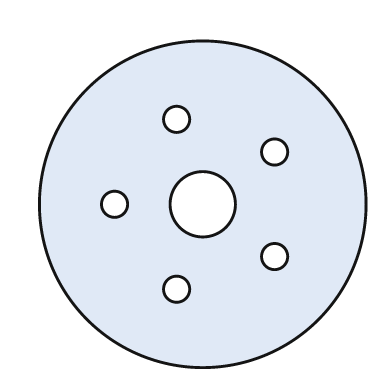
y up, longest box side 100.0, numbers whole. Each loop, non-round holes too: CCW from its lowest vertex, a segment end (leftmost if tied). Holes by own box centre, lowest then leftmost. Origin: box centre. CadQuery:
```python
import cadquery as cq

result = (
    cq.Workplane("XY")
    .moveTo(0.0, 0.0)
    .circle(50.0)
    .moveTo(-8.0, -26.0)
    .circle(4.0)
    .moveTo(22.0, -16.0)
    .circle(4.0)
    .moveTo(-27.0, 0.0)
    .circle(4.0)
    .moveTo(0.0, 0.0)
    .circle(10.0)
    .moveTo(22.0, 16.0)
    .circle(4.0)
    .moveTo(-8.0, 26.0)
    .circle(4.0)
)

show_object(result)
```